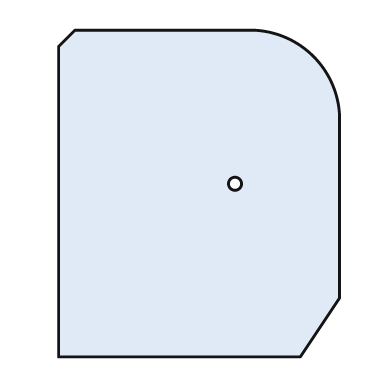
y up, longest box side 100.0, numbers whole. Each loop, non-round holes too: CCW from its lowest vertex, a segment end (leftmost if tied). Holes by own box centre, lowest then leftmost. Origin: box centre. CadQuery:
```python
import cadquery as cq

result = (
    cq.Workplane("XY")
    .moveTo(-43.0, -50.0)
    .lineTo(31.0, -50.0)
    .lineTo(43.0, -32.0)
    .lineTo(43.0, 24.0)
    .threePointArc((35.0, 42.0), (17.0, 50.0))
    .lineTo(-38.0, 50.0)
    .lineTo(-43.0, 45.0)
    .close()
    .moveTo(11.0, 3.0)
    .circle(2.0)
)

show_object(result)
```